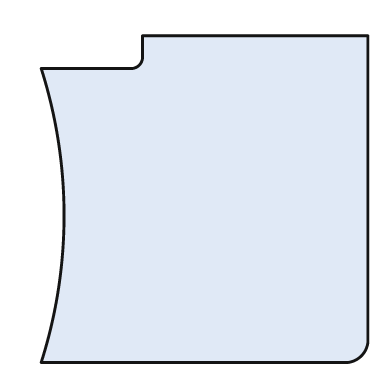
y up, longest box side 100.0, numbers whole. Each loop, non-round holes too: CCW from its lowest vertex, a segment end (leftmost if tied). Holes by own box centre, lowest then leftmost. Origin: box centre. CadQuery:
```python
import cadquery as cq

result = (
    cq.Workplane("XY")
    .moveTo(-50.0, -50.0)
    .lineTo(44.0, -50.0)
    .threePointArc((48.0, -48.0), (50.0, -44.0))
    .lineTo(50.0, 50.0)
    .lineTo(-19.0, 50.0)
    .lineTo(-19.0, 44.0)
    .threePointArc((-20.0, 41.0), (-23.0, 40.0))
    .lineTo(-50.0, 40.0)
    .threePointArc((-43.0, -5.0), (-50.0, -50.0))
    .close()
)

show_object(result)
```